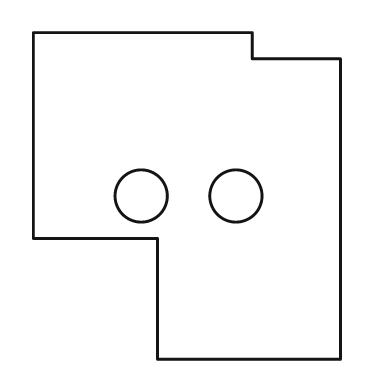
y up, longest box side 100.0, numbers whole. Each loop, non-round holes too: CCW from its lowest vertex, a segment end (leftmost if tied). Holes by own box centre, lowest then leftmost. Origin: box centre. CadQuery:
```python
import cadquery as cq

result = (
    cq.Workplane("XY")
    .moveTo(-9.0, -50.0)
    .lineTo(47.0, -50.0)
    .lineTo(47.0, 42.0)
    .lineTo(20.0, 42.0)
    .lineTo(20.0, 50.0)
    .lineTo(-47.0, 50.0)
    .lineTo(-47.0, -13.0)
    .lineTo(-9.0, -13.0)
    .close()
    .moveTo(-14.0, 0.0)
    .circle(8.0)
    .moveTo(15.0, 0.0)
    .circle(8.0)
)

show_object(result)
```